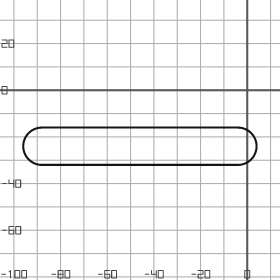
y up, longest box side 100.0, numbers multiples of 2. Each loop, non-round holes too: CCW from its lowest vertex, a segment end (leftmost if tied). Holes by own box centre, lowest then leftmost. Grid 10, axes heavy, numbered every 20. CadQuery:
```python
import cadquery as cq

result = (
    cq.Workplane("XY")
    .moveTo(-88.0, -32.0)
    .lineTo(-4.0, -32.0)
    .threePointArc((4.0, -24.0), (-4.0, -16.0))
    .lineTo(-88.0, -16.0)
    .threePointArc((-96.0, -24.0), (-88.0, -32.0))
    .close()
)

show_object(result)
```